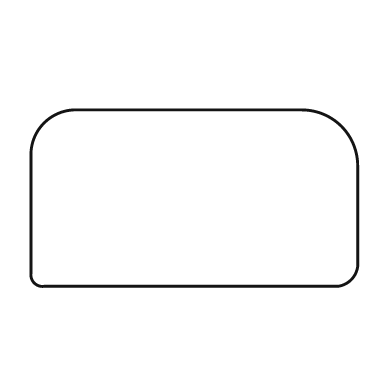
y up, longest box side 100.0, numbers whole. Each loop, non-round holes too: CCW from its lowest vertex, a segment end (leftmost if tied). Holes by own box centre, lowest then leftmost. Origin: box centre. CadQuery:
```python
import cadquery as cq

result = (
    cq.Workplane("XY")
    .moveTo(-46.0, -27.0)
    .lineTo(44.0, -27.0)
    .threePointArc((48.0, -25.0), (50.0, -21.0))
    .lineTo(50.0, 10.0)
    .threePointArc((45.0, 22.0), (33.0, 27.0))
    .lineTo(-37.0, 27.0)
    .threePointArc((-46.0, 23.0), (-50.0, 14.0))
    .lineTo(-50.0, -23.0)
    .threePointArc((-49.0, -26.0), (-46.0, -27.0))
    .close()
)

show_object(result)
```